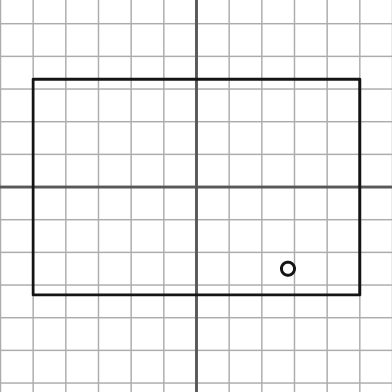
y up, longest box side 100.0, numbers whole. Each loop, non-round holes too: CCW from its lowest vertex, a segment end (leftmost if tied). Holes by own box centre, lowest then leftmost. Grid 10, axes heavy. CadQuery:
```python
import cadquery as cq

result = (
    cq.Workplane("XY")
    .moveTo(-50.0, -33.0)
    .lineTo(50.0, -33.0)
    .lineTo(50.0, 33.0)
    .lineTo(-50.0, 33.0)
    .close()
    .moveTo(28.0, -25.0)
    .circle(2.0)
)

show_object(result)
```